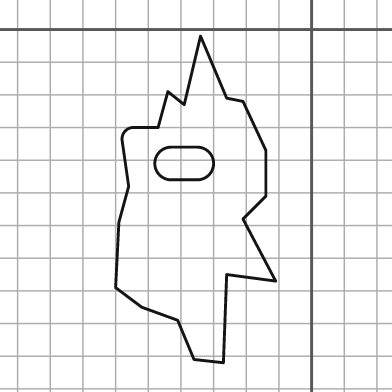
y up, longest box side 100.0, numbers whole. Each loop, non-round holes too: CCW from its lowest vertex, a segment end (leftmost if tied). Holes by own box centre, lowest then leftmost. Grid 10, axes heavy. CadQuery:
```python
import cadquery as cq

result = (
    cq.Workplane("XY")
    .moveTo(-27.0, -102.0)
    .lineTo(-26.0, -75.0)
    .lineTo(-11.0, -77.0)
    .lineTo(-21.0, -58.0)
    .lineTo(-14.0, -51.0)
    .lineTo(-14.0, -37.0)
    .lineTo(-21.0, -22.0)
    .lineTo(-26.0, -21.0)
    .lineTo(-34.0, -2.0)
    .lineTo(-39.0, -23.0)
    .lineTo(-44.0, -19.0)
    .lineTo(-47.0, -30.0)
    .lineTo(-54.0, -30.0)
    .threePointArc((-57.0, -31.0), (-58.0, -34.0))
    .lineTo(-56.0, -48.0)
    .lineTo(-59.0, -59.0)
    .lineTo(-60.0, -79.0)
    .lineTo(-52.0, -85.0)
    .lineTo(-41.0, -89.0)
    .lineTo(-36.0, -101.0)
    .close()
    .moveTo(-43.0, -46.0)
    .lineTo(-35.0, -46.0)
    .threePointArc((-30.0, -41.0), (-35.0, -36.0))
    .lineTo(-43.0, -36.0)
    .threePointArc((-48.0, -41.0), (-43.0, -46.0))
    .close()
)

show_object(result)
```